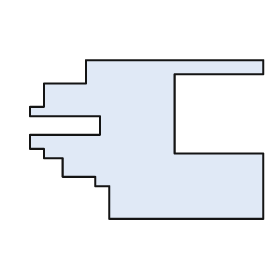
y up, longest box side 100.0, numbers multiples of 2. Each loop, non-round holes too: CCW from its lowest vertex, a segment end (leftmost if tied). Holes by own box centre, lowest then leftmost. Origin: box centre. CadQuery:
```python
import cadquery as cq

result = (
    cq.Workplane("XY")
    .moveTo(-16.0, -34.0)
    .lineTo(50.0, -34.0)
    .lineTo(50.0, -6.0)
    .lineTo(12.0, -6.0)
    .lineTo(12.0, 28.0)
    .lineTo(50.0, 28.0)
    .lineTo(50.0, 34.0)
    .lineTo(-26.0, 34.0)
    .lineTo(-26.0, 24.0)
    .lineTo(-44.0, 24.0)
    .lineTo(-44.0, 14.0)
    .lineTo(-50.0, 14.0)
    .lineTo(-50.0, 10.0)
    .lineTo(-20.0, 10.0)
    .lineTo(-20.0, 2.0)
    .lineTo(-50.0, 2.0)
    .lineTo(-50.0, -4.0)
    .lineTo(-44.0, -4.0)
    .lineTo(-44.0, -8.0)
    .lineTo(-36.0, -8.0)
    .lineTo(-36.0, -16.0)
    .lineTo(-22.0, -16.0)
    .lineTo(-22.0, -20.0)
    .lineTo(-16.0, -20.0)
    .close()
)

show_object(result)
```